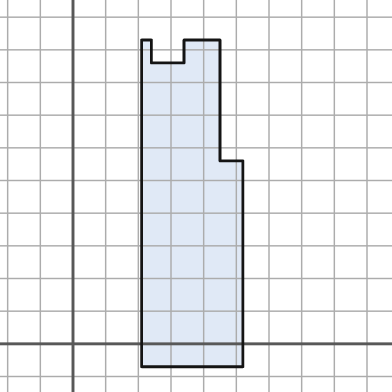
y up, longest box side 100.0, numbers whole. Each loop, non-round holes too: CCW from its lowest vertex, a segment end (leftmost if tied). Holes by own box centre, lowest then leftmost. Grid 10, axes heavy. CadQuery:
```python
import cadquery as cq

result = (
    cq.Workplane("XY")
    .moveTo(21.0, -7.0)
    .lineTo(52.0, -7.0)
    .lineTo(52.0, 56.0)
    .lineTo(45.0, 56.0)
    .lineTo(45.0, 93.0)
    .lineTo(34.0, 93.0)
    .lineTo(34.0, 86.0)
    .lineTo(24.0, 86.0)
    .lineTo(24.0, 93.0)
    .lineTo(21.0, 93.0)
    .close()
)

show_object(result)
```